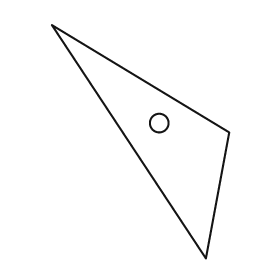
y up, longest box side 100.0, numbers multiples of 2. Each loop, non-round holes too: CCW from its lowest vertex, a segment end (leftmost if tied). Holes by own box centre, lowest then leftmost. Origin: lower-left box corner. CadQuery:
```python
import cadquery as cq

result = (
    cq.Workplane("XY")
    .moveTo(66.0, 0.0)
    .lineTo(76.0, 54.0)
    .lineTo(0.0, 100.0)
    .close()
    .moveTo(46.0, 58.0)
    .circle(4.0)
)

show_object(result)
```